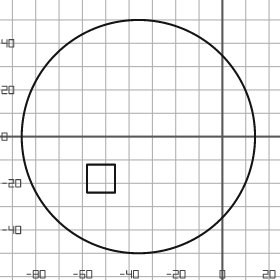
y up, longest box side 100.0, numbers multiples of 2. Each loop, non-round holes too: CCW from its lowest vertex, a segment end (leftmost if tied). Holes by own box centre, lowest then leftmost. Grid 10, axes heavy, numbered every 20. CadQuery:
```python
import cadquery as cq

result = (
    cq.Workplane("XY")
    .moveTo(-36.0, 0.0)
    .circle(50.0)
    .moveTo(-58.0, -24.0)
    .lineTo(-46.0, -24.0)
    .lineTo(-46.0, -12.0)
    .lineTo(-58.0, -12.0)
    .close()
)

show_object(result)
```